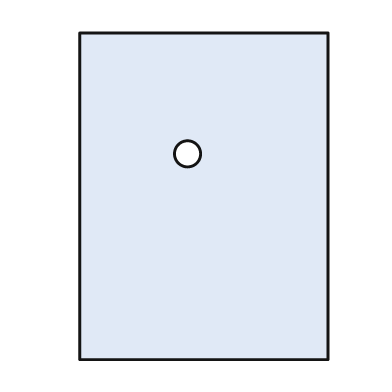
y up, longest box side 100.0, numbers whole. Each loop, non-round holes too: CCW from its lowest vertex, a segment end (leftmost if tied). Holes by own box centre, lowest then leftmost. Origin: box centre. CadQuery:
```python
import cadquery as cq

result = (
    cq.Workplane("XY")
    .moveTo(-38.0, -50.0)
    .lineTo(38.0, -50.0)
    .lineTo(38.0, 50.0)
    .lineTo(-38.0, 50.0)
    .close()
    .moveTo(-5.0, 13.0)
    .circle(4.0)
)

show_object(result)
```